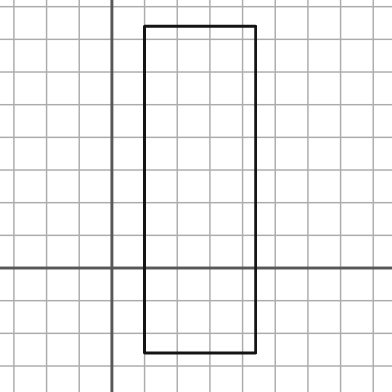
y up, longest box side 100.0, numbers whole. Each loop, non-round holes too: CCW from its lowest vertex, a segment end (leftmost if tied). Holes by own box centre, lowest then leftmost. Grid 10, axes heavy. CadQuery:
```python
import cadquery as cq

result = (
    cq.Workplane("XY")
    .moveTo(10.0, -26.0)
    .lineTo(44.0, -26.0)
    .lineTo(44.0, 74.0)
    .lineTo(10.0, 74.0)
    .close()
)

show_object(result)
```